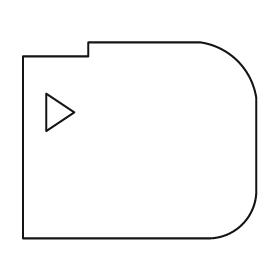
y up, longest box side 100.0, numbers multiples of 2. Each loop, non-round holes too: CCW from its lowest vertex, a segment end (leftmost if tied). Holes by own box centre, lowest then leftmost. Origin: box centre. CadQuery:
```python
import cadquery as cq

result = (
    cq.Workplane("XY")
    .moveTo(-50.0, -42.0)
    .lineTo(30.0, -42.0)
    .threePointArc((44.0, -36.0), (50.0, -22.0))
    .lineTo(50.0, 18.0)
    .threePointArc((42.0, 34.0), (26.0, 42.0))
    .lineTo(-22.0, 42.0)
    .lineTo(-22.0, 36.0)
    .lineTo(-50.0, 36.0)
    .close()
    .moveTo(-40.0, 4.0)
    .lineTo(-28.0, 12.0)
    .lineTo(-40.0, 20.0)
    .close()
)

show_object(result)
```